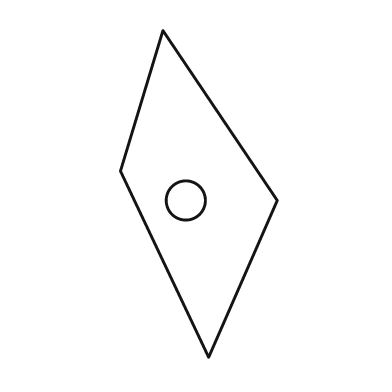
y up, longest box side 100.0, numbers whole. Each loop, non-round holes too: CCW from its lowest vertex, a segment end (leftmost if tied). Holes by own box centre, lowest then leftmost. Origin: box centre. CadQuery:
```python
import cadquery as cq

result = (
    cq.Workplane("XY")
    .moveTo(3.0, -50.0)
    .lineTo(24.0, -2.0)
    .lineTo(-11.0, 50.0)
    .lineTo(-24.0, 7.0)
    .close()
    .moveTo(-4.0, -2.0)
    .circle(6.0)
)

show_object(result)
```